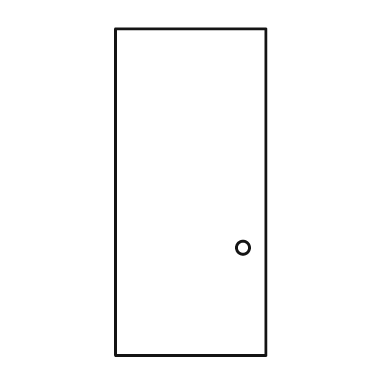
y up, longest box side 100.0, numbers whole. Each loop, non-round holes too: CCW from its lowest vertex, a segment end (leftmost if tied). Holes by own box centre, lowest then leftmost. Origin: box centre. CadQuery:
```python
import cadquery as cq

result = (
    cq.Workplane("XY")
    .moveTo(-23.0, -50.0)
    .lineTo(23.0, -50.0)
    .lineTo(23.0, 50.0)
    .lineTo(-23.0, 50.0)
    .close()
    .moveTo(16.0, -17.0)
    .circle(2.0)
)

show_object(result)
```